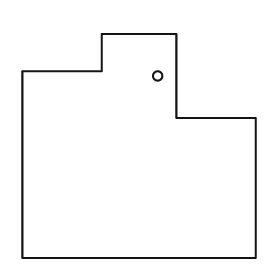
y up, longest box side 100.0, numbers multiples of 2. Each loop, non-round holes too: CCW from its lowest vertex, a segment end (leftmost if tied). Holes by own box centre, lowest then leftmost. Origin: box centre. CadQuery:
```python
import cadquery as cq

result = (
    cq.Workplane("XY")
    .moveTo(-50.0, -48.0)
    .lineTo(50.0, -48.0)
    .lineTo(50.0, 12.0)
    .lineTo(16.0, 12.0)
    .lineTo(16.0, 48.0)
    .lineTo(-16.0, 48.0)
    .lineTo(-16.0, 32.0)
    .lineTo(-50.0, 32.0)
    .close()
    .moveTo(8.0, 30.0)
    .circle(2.0)
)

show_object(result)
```